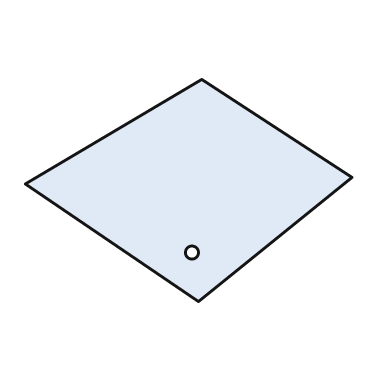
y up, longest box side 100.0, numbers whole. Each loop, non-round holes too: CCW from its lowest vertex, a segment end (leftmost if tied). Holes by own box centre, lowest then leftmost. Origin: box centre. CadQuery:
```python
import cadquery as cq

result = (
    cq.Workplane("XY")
    .moveTo(3.0, -34.0)
    .lineTo(50.0, 4.0)
    .lineTo(4.0, 34.0)
    .lineTo(-50.0, 2.0)
    .close()
    .moveTo(1.0, -19.0)
    .circle(2.0)
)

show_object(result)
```